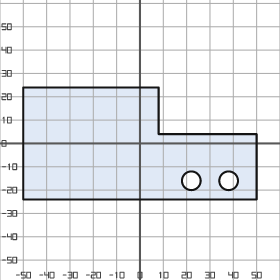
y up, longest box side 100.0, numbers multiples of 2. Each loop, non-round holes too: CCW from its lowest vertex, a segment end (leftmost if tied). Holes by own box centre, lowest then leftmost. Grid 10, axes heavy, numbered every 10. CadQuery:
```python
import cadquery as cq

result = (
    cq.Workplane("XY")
    .moveTo(-50.0, -24.0)
    .lineTo(50.0, -24.0)
    .lineTo(50.0, 4.0)
    .lineTo(8.0, 4.0)
    .lineTo(8.0, 24.0)
    .lineTo(-50.0, 24.0)
    .close()
    .moveTo(22.0, -16.0)
    .circle(4.0)
    .moveTo(38.0, -16.0)
    .circle(4.0)
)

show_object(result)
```